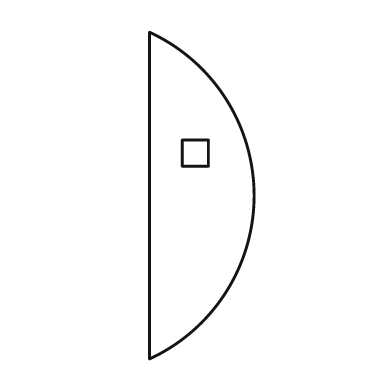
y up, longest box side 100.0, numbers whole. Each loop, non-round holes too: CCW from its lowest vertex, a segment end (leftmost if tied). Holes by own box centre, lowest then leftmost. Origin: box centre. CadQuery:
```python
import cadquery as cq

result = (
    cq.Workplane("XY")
    .moveTo(-16.0, -50.0)
    .threePointArc((16.0, 0.0), (-16.0, 50.0))
    .close()
    .moveTo(-6.0, 9.0)
    .lineTo(2.0, 9.0)
    .lineTo(2.0, 17.0)
    .lineTo(-6.0, 17.0)
    .close()
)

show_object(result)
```